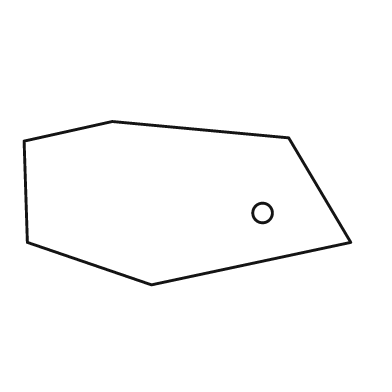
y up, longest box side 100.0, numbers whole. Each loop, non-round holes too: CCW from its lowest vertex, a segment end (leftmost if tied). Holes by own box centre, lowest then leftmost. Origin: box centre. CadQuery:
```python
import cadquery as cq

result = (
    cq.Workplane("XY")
    .moveTo(-11.0, -25.0)
    .lineTo(50.0, -12.0)
    .lineTo(31.0, 20.0)
    .lineTo(-23.0, 25.0)
    .lineTo(-50.0, 19.0)
    .lineTo(-49.0, -12.0)
    .close()
    .moveTo(23.0, -3.0)
    .circle(3.0)
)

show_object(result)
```